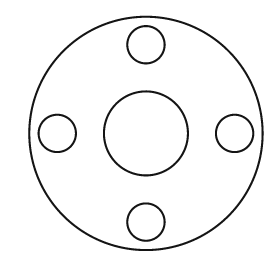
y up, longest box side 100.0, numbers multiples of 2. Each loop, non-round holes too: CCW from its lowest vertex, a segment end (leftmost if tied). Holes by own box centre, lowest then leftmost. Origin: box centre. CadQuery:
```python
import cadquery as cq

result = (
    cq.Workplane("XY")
    .moveTo(0.0, 0.0)
    .circle(50.0)
    .moveTo(0.0, -38.0)
    .circle(8.0)
    .moveTo(-38.0, 0.0)
    .circle(8.0)
    .moveTo(0.0, 0.0)
    .circle(18.0)
    .moveTo(38.0, 0.0)
    .circle(8.0)
    .moveTo(0.0, 38.0)
    .circle(8.0)
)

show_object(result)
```